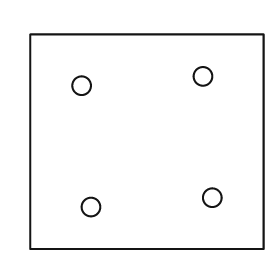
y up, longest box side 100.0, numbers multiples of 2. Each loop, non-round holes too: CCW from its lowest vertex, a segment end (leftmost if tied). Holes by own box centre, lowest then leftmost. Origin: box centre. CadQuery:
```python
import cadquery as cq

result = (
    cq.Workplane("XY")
    .moveTo(-50.0, -46.0)
    .lineTo(50.0, -46.0)
    .lineTo(50.0, 46.0)
    .lineTo(-50.0, 46.0)
    .close()
    .moveTo(-24.0, -28.0)
    .circle(4.0)
    .moveTo(28.0, -24.0)
    .circle(4.0)
    .moveTo(-28.0, 24.0)
    .circle(4.0)
    .moveTo(24.0, 28.0)
    .circle(4.0)
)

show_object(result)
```